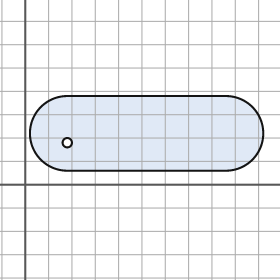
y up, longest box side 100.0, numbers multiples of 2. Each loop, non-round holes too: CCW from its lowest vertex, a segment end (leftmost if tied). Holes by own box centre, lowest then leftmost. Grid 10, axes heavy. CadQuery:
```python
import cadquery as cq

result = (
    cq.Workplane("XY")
    .moveTo(18.0, 6.0)
    .lineTo(86.0, 6.0)
    .threePointArc((102.0, 22.0), (86.0, 38.0))
    .lineTo(18.0, 38.0)
    .threePointArc((2.0, 22.0), (18.0, 6.0))
    .close()
    .moveTo(18.0, 18.0)
    .circle(2.0)
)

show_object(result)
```